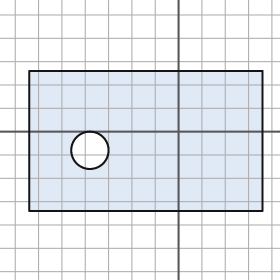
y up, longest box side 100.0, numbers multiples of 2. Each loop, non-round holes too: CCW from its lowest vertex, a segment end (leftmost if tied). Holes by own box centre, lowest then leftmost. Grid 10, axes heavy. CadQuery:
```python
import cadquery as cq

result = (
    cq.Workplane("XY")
    .moveTo(-64.0, -34.0)
    .lineTo(36.0, -34.0)
    .lineTo(36.0, 26.0)
    .lineTo(-64.0, 26.0)
    .close()
    .moveTo(-38.0, -8.0)
    .circle(8.0)
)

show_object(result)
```